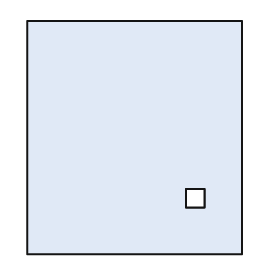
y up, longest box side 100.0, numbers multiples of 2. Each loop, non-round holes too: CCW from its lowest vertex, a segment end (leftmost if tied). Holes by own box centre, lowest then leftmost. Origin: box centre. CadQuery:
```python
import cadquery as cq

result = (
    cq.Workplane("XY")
    .moveTo(-46.0, -50.0)
    .lineTo(46.0, -50.0)
    .lineTo(46.0, 50.0)
    .lineTo(-46.0, 50.0)
    .close()
    .moveTo(22.0, -30.0)
    .lineTo(30.0, -30.0)
    .lineTo(30.0, -22.0)
    .lineTo(22.0, -22.0)
    .close()
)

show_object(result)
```